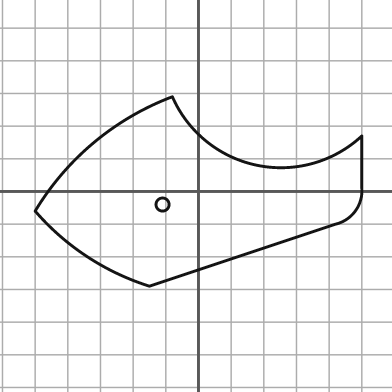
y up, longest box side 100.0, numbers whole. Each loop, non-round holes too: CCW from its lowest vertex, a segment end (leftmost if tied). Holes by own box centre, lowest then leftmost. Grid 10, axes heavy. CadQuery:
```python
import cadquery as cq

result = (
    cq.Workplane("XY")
    .moveTo(-15.0, -29.0)
    .lineTo(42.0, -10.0)
    .threePointArc((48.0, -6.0), (50.0, 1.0))
    .lineTo(50.0, 17.0)
    .threePointArc((18.0, 8.0), (-8.0, 29.0))
    .threePointArc((-32.0, 15.0), (-50.0, -6.0))
    .threePointArc((-34.0, -20.0), (-15.0, -29.0))
    .close()
    .moveTo(-11.0, -4.0)
    .circle(2.0)
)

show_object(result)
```